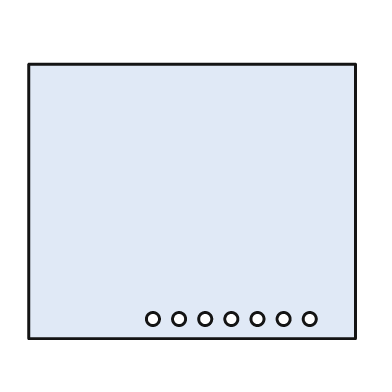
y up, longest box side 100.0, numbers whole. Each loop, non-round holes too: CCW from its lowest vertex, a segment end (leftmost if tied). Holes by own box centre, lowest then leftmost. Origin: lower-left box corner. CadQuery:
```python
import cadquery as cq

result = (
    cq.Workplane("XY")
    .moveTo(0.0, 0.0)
    .lineTo(100.0, 0.0)
    .lineTo(100.0, 84.0)
    .lineTo(0.0, 84.0)
    .close()
    .moveTo(38.0, 6.0)
    .circle(2.0)
    .moveTo(46.0, 6.0)
    .circle(2.0)
    .moveTo(54.0, 6.0)
    .circle(2.0)
    .moveTo(62.0, 6.0)
    .circle(2.0)
    .moveTo(70.0, 6.0)
    .circle(2.0)
    .moveTo(78.0, 6.0)
    .circle(2.0)
    .moveTo(86.0, 6.0)
    .circle(2.0)
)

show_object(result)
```